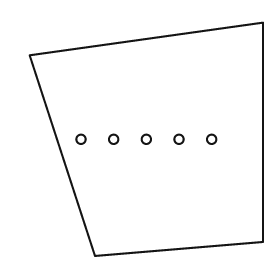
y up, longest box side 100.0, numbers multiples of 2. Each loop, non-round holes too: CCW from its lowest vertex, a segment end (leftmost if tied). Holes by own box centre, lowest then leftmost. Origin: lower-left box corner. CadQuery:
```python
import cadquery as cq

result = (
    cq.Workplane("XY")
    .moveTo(28.0, 0.0)
    .lineTo(100.0, 6.0)
    .lineTo(100.0, 100.0)
    .lineTo(0.0, 86.0)
    .close()
    .moveTo(22.0, 50.0)
    .circle(2.0)
    .moveTo(36.0, 50.0)
    .circle(2.0)
    .moveTo(50.0, 50.0)
    .circle(2.0)
    .moveTo(64.0, 50.0)
    .circle(2.0)
    .moveTo(78.0, 50.0)
    .circle(2.0)
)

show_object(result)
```